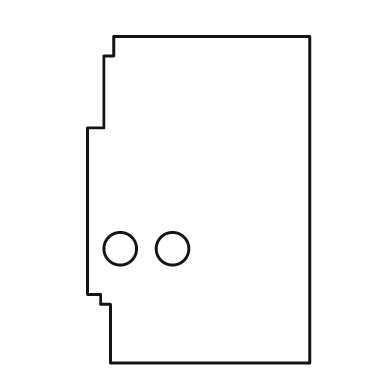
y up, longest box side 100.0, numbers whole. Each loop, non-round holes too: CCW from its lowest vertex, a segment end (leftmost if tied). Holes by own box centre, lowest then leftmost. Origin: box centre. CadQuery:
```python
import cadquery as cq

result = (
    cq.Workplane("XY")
    .moveTo(-27.0, -50.0)
    .lineTo(34.0, -50.0)
    .lineTo(34.0, 50.0)
    .lineTo(-26.0, 50.0)
    .lineTo(-26.0, 44.0)
    .lineTo(-29.0, 44.0)
    .lineTo(-29.0, 22.0)
    .lineTo(-34.0, 22.0)
    .lineTo(-34.0, -29.0)
    .lineTo(-30.0, -29.0)
    .lineTo(-30.0, -32.0)
    .lineTo(-27.0, -32.0)
    .close()
    .moveTo(-24.0, -15.0)
    .circle(5.0)
    .moveTo(-8.0, -15.0)
    .circle(5.0)
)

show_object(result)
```